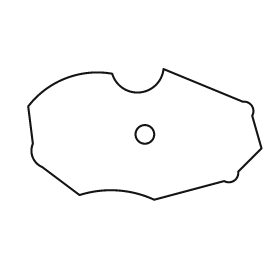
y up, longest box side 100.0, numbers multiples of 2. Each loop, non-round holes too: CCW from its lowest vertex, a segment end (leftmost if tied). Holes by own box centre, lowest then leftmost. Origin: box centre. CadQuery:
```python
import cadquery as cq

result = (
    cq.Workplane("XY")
    .moveTo(4.0, -28.0)
    .lineTo(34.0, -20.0)
    .threePointArc((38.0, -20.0), (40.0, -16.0))
    .lineTo(50.0, -6.0)
    .lineTo(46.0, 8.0)
    .threePointArc((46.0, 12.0), (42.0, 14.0))
    .lineTo(8.0, 28.0)
    .threePointArc((-2.0, 18.0), (-14.0, 26.0))
    .threePointArc((-34.0, 24.0), (-50.0, 12.0))
    .lineTo(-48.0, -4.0)
    .threePointArc((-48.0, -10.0), (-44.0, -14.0))
    .lineTo(-28.0, -26.0)
    .threePointArc((-12.0, -24.0), (4.0, -28.0))
    .close()
    .moveTo(0.0, 0.0)
    .circle(4.0)
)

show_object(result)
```